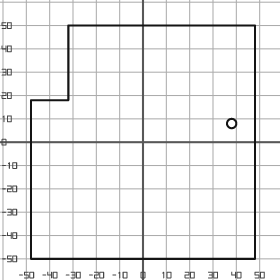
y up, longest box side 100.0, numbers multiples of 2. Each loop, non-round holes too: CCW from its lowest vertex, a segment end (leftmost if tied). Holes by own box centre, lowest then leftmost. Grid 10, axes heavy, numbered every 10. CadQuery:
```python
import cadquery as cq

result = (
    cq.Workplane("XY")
    .moveTo(-48.0, -50.0)
    .lineTo(48.0, -50.0)
    .lineTo(48.0, 50.0)
    .lineTo(-32.0, 50.0)
    .lineTo(-32.0, 18.0)
    .lineTo(-48.0, 18.0)
    .close()
    .moveTo(38.0, 8.0)
    .circle(2.0)
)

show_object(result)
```